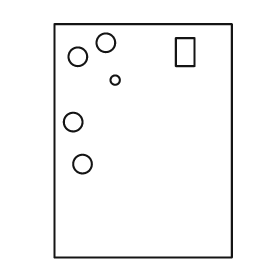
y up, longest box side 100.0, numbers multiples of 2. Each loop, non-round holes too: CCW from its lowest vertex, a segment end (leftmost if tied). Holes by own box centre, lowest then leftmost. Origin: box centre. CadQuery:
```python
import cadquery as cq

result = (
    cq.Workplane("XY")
    .moveTo(-38.0, -50.0)
    .lineTo(38.0, -50.0)
    .lineTo(38.0, 50.0)
    .lineTo(-38.0, 50.0)
    .close()
    .moveTo(-26.0, -10.0)
    .circle(4.0)
    .moveTo(-30.0, 8.0)
    .circle(4.0)
    .moveTo(-12.0, 26.0)
    .circle(2.0)
    .moveTo(-28.0, 36.0)
    .circle(4.0)
    .moveTo(14.0, 32.0)
    .lineTo(22.0, 32.0)
    .lineTo(22.0, 44.0)
    .lineTo(14.0, 44.0)
    .close()
    .moveTo(-16.0, 42.0)
    .circle(4.0)
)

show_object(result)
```